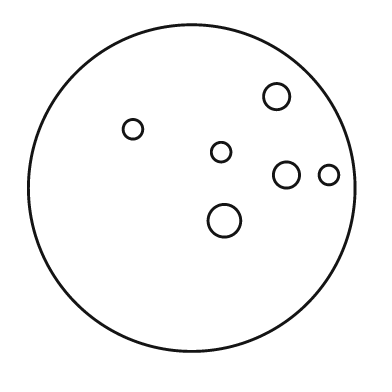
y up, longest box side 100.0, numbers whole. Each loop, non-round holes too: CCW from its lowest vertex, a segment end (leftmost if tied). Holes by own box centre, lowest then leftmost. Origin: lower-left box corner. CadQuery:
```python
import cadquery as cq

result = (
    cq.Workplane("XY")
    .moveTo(50.0, 50.0)
    .circle(50.0)
    .moveTo(60.0, 40.0)
    .circle(5.0)
    .moveTo(79.0, 54.0)
    .circle(4.0)
    .moveTo(92.0, 54.0)
    .circle(3.0)
    .moveTo(59.0, 61.0)
    .circle(3.0)
    .moveTo(32.0, 68.0)
    .circle(3.0)
    .moveTo(76.0, 78.0)
    .circle(4.0)
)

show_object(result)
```